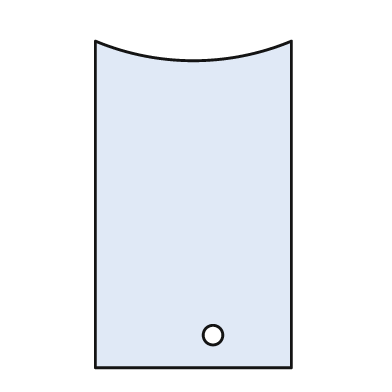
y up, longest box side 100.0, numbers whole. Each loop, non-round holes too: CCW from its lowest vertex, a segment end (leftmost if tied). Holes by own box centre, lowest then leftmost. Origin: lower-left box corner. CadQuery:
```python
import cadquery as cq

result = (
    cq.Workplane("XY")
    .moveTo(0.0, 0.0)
    .lineTo(60.0, 0.0)
    .lineTo(60.0, 100.0)
    .threePointArc((30.0, 94.0), (0.0, 100.0))
    .close()
    .moveTo(36.0, 10.0)
    .circle(3.0)
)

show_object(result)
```